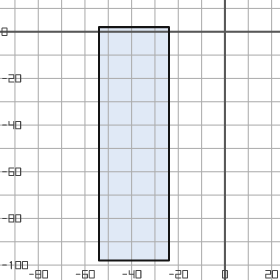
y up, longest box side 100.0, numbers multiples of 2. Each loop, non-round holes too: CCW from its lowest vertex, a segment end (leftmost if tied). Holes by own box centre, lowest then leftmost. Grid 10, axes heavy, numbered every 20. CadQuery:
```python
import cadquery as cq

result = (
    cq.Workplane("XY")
    .moveTo(-54.0, -98.0)
    .lineTo(-24.0, -98.0)
    .lineTo(-24.0, 2.0)
    .lineTo(-54.0, 2.0)
    .close()
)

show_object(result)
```